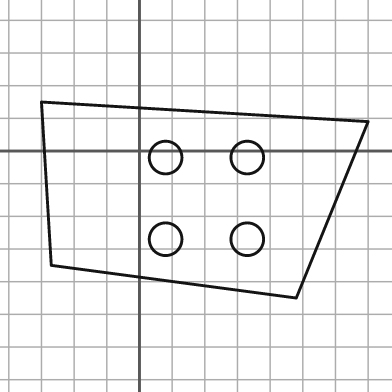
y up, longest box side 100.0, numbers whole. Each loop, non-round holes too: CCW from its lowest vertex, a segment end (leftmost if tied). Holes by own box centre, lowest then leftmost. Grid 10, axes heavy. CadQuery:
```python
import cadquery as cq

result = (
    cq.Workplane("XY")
    .moveTo(48.0, -45.0)
    .lineTo(70.0, 9.0)
    .lineTo(-30.0, 15.0)
    .lineTo(-27.0, -35.0)
    .close()
    .moveTo(8.0, -27.0)
    .circle(5.0)
    .moveTo(33.0, -27.0)
    .circle(5.0)
    .moveTo(8.0, -2.0)
    .circle(5.0)
    .moveTo(33.0, -2.0)
    .circle(5.0)
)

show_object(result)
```